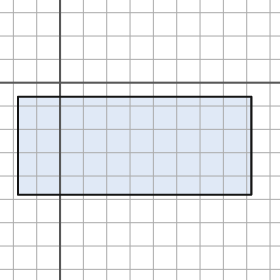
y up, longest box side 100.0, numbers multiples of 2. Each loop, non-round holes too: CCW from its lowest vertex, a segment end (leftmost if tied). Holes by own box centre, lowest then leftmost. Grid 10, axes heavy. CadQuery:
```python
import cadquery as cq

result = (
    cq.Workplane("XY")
    .moveTo(-18.0, -48.0)
    .lineTo(82.0, -48.0)
    .lineTo(82.0, -6.0)
    .lineTo(-18.0, -6.0)
    .close()
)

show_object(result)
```